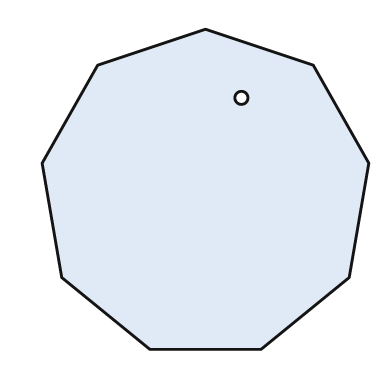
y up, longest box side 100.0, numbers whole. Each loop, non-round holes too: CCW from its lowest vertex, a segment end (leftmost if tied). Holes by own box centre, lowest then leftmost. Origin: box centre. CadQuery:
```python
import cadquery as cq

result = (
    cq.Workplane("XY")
    .moveTo(-17.0, -49.0)
    .lineTo(17.0, -49.0)
    .lineTo(44.0, -27.0)
    .lineTo(50.0, 8.0)
    .lineTo(33.0, 38.0)
    .lineTo(0.0, 49.0)
    .lineTo(-33.0, 38.0)
    .lineTo(-50.0, 8.0)
    .lineTo(-44.0, -27.0)
    .close()
    .moveTo(11.0, 28.0)
    .circle(2.0)
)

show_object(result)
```